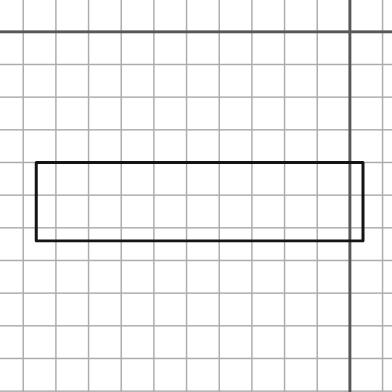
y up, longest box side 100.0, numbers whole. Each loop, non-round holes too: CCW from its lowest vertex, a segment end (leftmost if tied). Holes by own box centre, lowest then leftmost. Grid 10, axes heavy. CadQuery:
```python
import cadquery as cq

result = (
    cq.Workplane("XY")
    .moveTo(-96.0, -64.0)
    .lineTo(4.0, -64.0)
    .lineTo(4.0, -40.0)
    .lineTo(-96.0, -40.0)
    .close()
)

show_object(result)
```